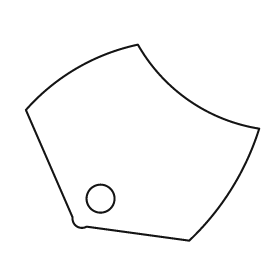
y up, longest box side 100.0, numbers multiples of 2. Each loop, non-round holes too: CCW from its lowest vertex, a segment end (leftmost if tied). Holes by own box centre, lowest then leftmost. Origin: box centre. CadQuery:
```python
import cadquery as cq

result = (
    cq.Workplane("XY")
    .moveTo(20.0, -42.0)
    .threePointArc((38.0, -20.0), (50.0, 6.0))
    .threePointArc((20.0, 18.0), (-2.0, 42.0))
    .threePointArc((-28.0, 32.0), (-50.0, 14.0))
    .lineTo(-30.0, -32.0)
    .threePointArc((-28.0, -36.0), (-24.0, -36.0))
    .close()
    .moveTo(-18.0, -24.0)
    .circle(6.0)
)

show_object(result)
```